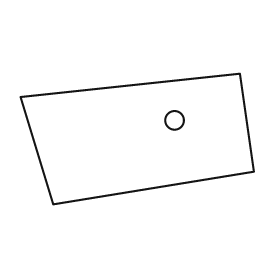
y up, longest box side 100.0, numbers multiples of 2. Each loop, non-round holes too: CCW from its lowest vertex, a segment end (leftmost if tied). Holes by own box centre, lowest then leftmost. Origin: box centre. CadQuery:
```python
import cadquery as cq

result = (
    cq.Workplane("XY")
    .moveTo(-36.0, -28.0)
    .lineTo(50.0, -14.0)
    .lineTo(44.0, 28.0)
    .lineTo(-50.0, 18.0)
    .close()
    .moveTo(16.0, 8.0)
    .circle(4.0)
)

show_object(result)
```